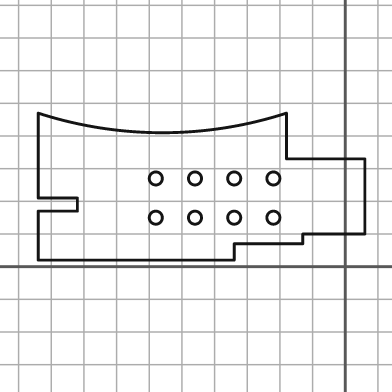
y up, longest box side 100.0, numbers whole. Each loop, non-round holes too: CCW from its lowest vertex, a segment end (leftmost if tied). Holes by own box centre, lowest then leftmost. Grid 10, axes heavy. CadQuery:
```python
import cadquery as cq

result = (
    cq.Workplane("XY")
    .moveTo(-94.0, 2.0)
    .lineTo(-34.0, 2.0)
    .lineTo(-34.0, 7.0)
    .lineTo(-13.0, 7.0)
    .lineTo(-13.0, 10.0)
    .lineTo(6.0, 10.0)
    .lineTo(6.0, 33.0)
    .lineTo(-18.0, 33.0)
    .lineTo(-18.0, 47.0)
    .threePointArc((-56.0, 41.0), (-94.0, 47.0))
    .lineTo(-94.0, 21.0)
    .lineTo(-82.0, 21.0)
    .lineTo(-82.0, 17.0)
    .lineTo(-94.0, 17.0)
    .close()
    .moveTo(-58.0, 15.0)
    .circle(2.0)
    .moveTo(-46.0, 15.0)
    .circle(2.0)
    .moveTo(-34.0, 15.0)
    .circle(2.0)
    .moveTo(-22.0, 15.0)
    .circle(2.0)
    .moveTo(-58.0, 27.0)
    .circle(2.0)
    .moveTo(-46.0, 27.0)
    .circle(2.0)
    .moveTo(-34.0, 27.0)
    .circle(2.0)
    .moveTo(-22.0, 27.0)
    .circle(2.0)
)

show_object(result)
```